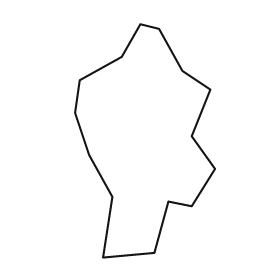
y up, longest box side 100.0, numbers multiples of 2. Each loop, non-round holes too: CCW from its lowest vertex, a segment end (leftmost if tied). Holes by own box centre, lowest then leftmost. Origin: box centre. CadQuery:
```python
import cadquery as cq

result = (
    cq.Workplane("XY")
    .moveTo(-18.0, -50.0)
    .lineTo(4.0, -48.0)
    .lineTo(10.0, -26.0)
    .lineTo(20.0, -28.0)
    .lineTo(30.0, -12.0)
    .lineTo(20.0, 2.0)
    .lineTo(28.0, 22.0)
    .lineTo(16.0, 30.0)
    .lineTo(6.0, 48.0)
    .lineTo(-2.0, 50.0)
    .lineTo(-10.0, 36.0)
    .lineTo(-28.0, 26.0)
    .lineTo(-30.0, 12.0)
    .lineTo(-24.0, -6.0)
    .lineTo(-14.0, -24.0)
    .close()
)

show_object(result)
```